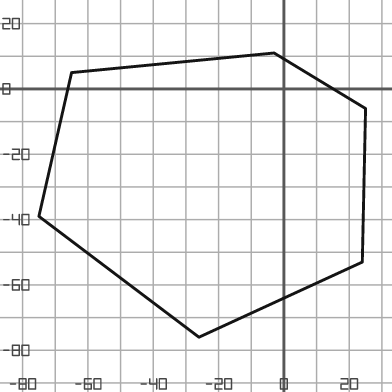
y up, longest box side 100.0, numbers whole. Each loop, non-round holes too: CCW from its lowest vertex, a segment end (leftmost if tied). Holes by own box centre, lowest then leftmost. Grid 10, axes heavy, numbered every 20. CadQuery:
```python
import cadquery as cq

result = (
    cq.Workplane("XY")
    .moveTo(-26.0, -76.0)
    .lineTo(24.0, -53.0)
    .lineTo(25.0, -6.0)
    .lineTo(-3.0, 11.0)
    .lineTo(-65.0, 5.0)
    .lineTo(-75.0, -39.0)
    .close()
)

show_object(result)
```